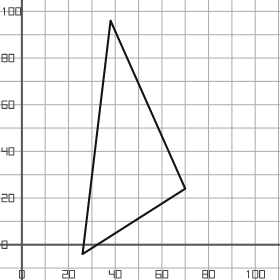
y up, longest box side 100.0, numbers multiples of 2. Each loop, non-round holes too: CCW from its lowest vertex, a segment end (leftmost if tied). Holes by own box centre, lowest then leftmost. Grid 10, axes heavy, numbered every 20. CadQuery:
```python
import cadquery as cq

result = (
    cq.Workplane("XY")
    .moveTo(26.0, -4.0)
    .lineTo(70.0, 24.0)
    .lineTo(38.0, 96.0)
    .close()
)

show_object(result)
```